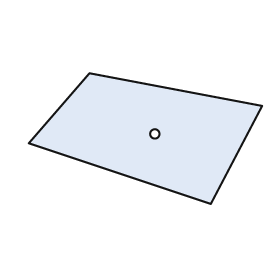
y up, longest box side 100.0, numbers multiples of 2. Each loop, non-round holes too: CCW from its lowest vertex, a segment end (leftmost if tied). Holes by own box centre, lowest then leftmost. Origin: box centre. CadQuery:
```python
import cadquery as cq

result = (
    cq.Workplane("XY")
    .moveTo(28.0, -28.0)
    .lineTo(50.0, 14.0)
    .lineTo(-24.0, 28.0)
    .lineTo(-50.0, -2.0)
    .close()
    .moveTo(4.0, 2.0)
    .circle(2.0)
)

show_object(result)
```